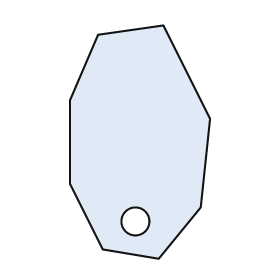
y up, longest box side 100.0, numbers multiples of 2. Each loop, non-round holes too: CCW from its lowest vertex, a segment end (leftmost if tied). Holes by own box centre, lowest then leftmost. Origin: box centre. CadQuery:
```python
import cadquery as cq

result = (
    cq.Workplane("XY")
    .moveTo(8.0, -50.0)
    .lineTo(26.0, -28.0)
    .lineTo(30.0, 10.0)
    .lineTo(10.0, 50.0)
    .lineTo(-18.0, 46.0)
    .lineTo(-30.0, 18.0)
    .lineTo(-30.0, -18.0)
    .lineTo(-16.0, -46.0)
    .close()
    .moveTo(-2.0, -34.0)
    .circle(6.0)
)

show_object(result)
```